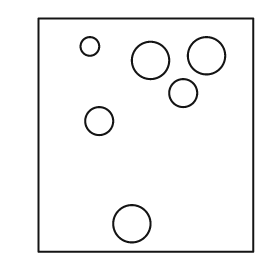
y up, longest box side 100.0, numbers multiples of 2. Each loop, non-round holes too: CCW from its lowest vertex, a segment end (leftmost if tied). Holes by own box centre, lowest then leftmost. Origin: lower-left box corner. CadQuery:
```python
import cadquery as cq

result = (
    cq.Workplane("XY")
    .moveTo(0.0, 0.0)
    .lineTo(92.0, 0.0)
    .lineTo(92.0, 100.0)
    .lineTo(0.0, 100.0)
    .close()
    .moveTo(40.0, 12.0)
    .circle(8.0)
    .moveTo(26.0, 56.0)
    .circle(6.0)
    .moveTo(62.0, 68.0)
    .circle(6.0)
    .moveTo(48.0, 82.0)
    .circle(8.0)
    .moveTo(72.0, 84.0)
    .circle(8.0)
    .moveTo(22.0, 88.0)
    .circle(4.0)
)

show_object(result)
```